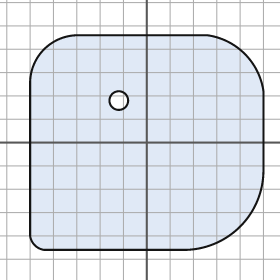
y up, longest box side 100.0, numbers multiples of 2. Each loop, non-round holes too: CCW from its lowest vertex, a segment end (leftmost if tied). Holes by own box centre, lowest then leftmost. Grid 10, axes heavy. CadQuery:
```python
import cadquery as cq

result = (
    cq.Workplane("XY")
    .moveTo(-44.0, -46.0)
    .lineTo(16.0, -46.0)
    .threePointArc((40.0, -36.0), (50.0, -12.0))
    .lineTo(50.0, 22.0)
    .threePointArc((42.0, 38.0), (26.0, 46.0))
    .lineTo(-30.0, 46.0)
    .threePointArc((-44.0, 40.0), (-50.0, 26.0))
    .lineTo(-50.0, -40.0)
    .threePointArc((-48.0, -44.0), (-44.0, -46.0))
    .close()
    .moveTo(-12.0, 18.0)
    .circle(4.0)
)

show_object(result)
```